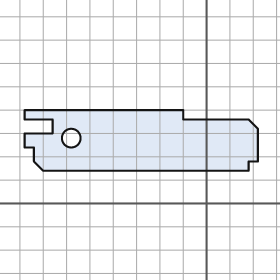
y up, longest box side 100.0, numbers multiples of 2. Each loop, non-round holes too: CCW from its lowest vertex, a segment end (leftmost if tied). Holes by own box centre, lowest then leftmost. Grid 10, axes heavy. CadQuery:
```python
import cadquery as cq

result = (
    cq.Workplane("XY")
    .moveTo(-70.0, 14.0)
    .lineTo(18.0, 14.0)
    .lineTo(18.0, 18.0)
    .lineTo(22.0, 18.0)
    .lineTo(22.0, 32.0)
    .lineTo(18.0, 36.0)
    .lineTo(-10.0, 36.0)
    .lineTo(-10.0, 40.0)
    .lineTo(-78.0, 40.0)
    .lineTo(-78.0, 36.0)
    .lineTo(-66.0, 36.0)
    .lineTo(-66.0, 30.0)
    .lineTo(-78.0, 30.0)
    .lineTo(-78.0, 24.0)
    .lineTo(-74.0, 24.0)
    .lineTo(-74.0, 18.0)
    .close()
    .moveTo(-58.0, 28.0)
    .circle(4.0)
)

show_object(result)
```